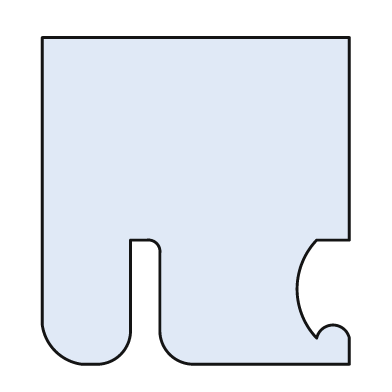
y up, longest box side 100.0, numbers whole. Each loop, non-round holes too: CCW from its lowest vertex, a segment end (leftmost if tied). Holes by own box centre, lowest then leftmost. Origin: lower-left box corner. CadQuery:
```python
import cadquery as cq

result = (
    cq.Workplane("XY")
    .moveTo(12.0, 0.0)
    .lineTo(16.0, 0.0)
    .threePointArc((24.0, 3.0), (27.0, 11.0))
    .lineTo(27.0, 38.0)
    .lineTo(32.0, 38.0)
    .threePointArc((35.0, 37.0), (36.0, 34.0))
    .lineTo(36.0, 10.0)
    .threePointArc((39.0, 3.0), (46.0, 0.0))
    .lineTo(94.0, 0.0)
    .lineTo(94.0, 8.0)
    .threePointArc((89.0, 12.0), (84.0, 8.0))
    .threePointArc((78.0, 23.0), (84.0, 38.0))
    .lineTo(94.0, 38.0)
    .lineTo(94.0, 100.0)
    .lineTo(0.0, 100.0)
    .lineTo(0.0, 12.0)
    .threePointArc((4.0, 4.0), (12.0, 0.0))
    .close()
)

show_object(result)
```